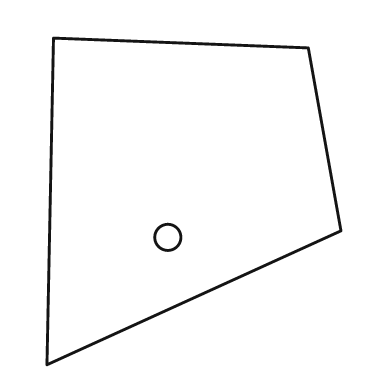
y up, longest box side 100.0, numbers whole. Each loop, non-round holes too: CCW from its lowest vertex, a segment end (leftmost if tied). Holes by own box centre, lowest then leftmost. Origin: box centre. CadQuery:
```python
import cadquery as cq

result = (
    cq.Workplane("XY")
    .moveTo(-45.0, -50.0)
    .lineTo(45.0, -9.0)
    .lineTo(35.0, 47.0)
    .lineTo(-43.0, 50.0)
    .close()
    .moveTo(-8.0, -11.0)
    .circle(4.0)
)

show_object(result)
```